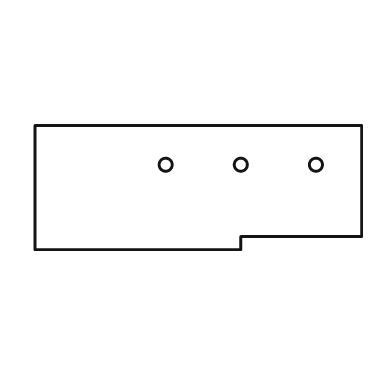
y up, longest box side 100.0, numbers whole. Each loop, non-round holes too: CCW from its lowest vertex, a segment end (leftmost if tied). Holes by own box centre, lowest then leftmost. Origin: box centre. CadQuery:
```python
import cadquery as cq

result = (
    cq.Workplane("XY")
    .moveTo(-50.0, -19.0)
    .lineTo(13.0, -19.0)
    .lineTo(13.0, -15.0)
    .lineTo(50.0, -15.0)
    .lineTo(50.0, 19.0)
    .lineTo(-50.0, 19.0)
    .close()
    .moveTo(-10.0, 7.0)
    .circle(2.0)
    .moveTo(13.0, 7.0)
    .circle(2.0)
    .moveTo(36.0, 7.0)
    .circle(2.0)
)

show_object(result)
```